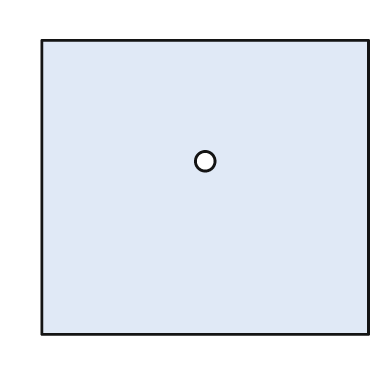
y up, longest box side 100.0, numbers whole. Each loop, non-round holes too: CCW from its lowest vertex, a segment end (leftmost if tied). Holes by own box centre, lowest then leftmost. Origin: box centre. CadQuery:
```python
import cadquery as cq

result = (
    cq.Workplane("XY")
    .moveTo(-50.0, -45.0)
    .lineTo(50.0, -45.0)
    .lineTo(50.0, 45.0)
    .lineTo(-50.0, 45.0)
    .close()
    .moveTo(0.0, 8.0)
    .circle(3.0)
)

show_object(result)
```